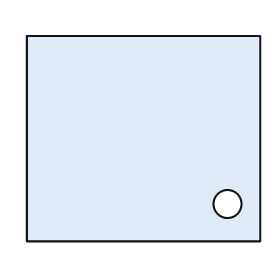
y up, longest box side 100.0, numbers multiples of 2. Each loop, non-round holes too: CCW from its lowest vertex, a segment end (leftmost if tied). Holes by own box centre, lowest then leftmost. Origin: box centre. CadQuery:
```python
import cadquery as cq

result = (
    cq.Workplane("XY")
    .moveTo(-50.0, -44.0)
    .lineTo(50.0, -44.0)
    .lineTo(50.0, 44.0)
    .lineTo(-50.0, 44.0)
    .close()
    .moveTo(36.0, -28.0)
    .circle(6.0)
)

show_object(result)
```